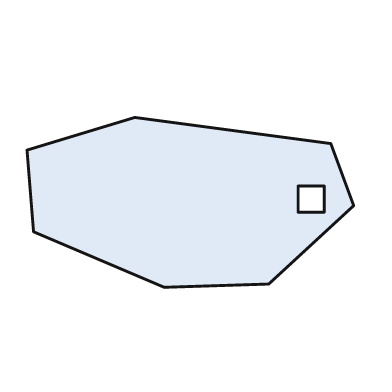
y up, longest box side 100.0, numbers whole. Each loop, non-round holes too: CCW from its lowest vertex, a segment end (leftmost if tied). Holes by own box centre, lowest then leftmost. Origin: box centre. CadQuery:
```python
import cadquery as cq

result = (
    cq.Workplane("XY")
    .moveTo(-8.0, -26.0)
    .lineTo(24.0, -25.0)
    .lineTo(50.0, -1.0)
    .lineTo(43.0, 18.0)
    .lineTo(-17.0, 26.0)
    .lineTo(-50.0, 16.0)
    .lineTo(-48.0, -9.0)
    .close()
    .moveTo(33.0, -3.0)
    .lineTo(41.0, -3.0)
    .lineTo(41.0, 5.0)
    .lineTo(33.0, 5.0)
    .close()
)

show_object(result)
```